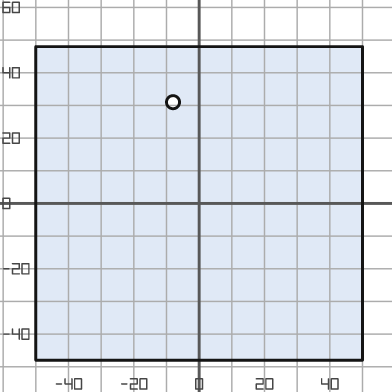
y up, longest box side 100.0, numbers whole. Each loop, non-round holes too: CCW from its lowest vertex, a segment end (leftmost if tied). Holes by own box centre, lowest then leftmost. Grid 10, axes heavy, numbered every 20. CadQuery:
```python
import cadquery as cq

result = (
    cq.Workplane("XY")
    .moveTo(-50.0, -48.0)
    .lineTo(50.0, -48.0)
    .lineTo(50.0, 48.0)
    .lineTo(-50.0, 48.0)
    .close()
    .moveTo(-8.0, 31.0)
    .circle(2.0)
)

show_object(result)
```